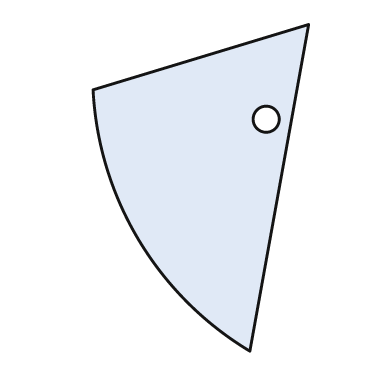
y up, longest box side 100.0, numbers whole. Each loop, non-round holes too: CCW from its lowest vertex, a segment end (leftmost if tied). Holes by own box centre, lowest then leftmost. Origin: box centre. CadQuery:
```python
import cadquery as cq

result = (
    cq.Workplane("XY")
    .moveTo(15.0, -50.0)
    .lineTo(33.0, 50.0)
    .lineTo(-33.0, 30.0)
    .threePointArc((-19.0, -16.0), (15.0, -50.0))
    .close()
    .moveTo(20.0, 21.0)
    .circle(4.0)
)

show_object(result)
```